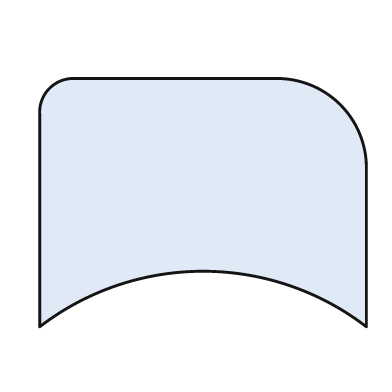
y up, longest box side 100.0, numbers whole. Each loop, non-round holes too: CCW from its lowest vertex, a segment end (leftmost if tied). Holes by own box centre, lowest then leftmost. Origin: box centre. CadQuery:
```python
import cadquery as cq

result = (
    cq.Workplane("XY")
    .moveTo(-50.0, -38.0)
    .threePointArc((0.0, -21.0), (50.0, -38.0))
    .lineTo(50.0, 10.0)
    .threePointArc((42.0, 30.0), (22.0, 38.0))
    .lineTo(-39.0, 38.0)
    .threePointArc((-47.0, 35.0), (-50.0, 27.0))
    .close()
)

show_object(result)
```